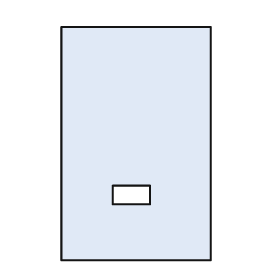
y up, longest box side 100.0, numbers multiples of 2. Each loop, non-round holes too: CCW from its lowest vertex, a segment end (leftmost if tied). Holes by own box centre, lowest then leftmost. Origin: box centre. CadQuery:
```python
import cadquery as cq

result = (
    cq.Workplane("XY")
    .moveTo(-32.0, -50.0)
    .lineTo(32.0, -50.0)
    .lineTo(32.0, 50.0)
    .lineTo(-32.0, 50.0)
    .close()
    .moveTo(-10.0, -26.0)
    .lineTo(6.0, -26.0)
    .lineTo(6.0, -18.0)
    .lineTo(-10.0, -18.0)
    .close()
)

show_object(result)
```